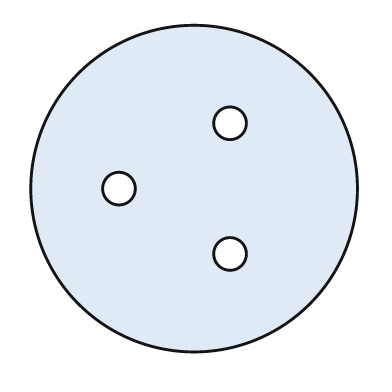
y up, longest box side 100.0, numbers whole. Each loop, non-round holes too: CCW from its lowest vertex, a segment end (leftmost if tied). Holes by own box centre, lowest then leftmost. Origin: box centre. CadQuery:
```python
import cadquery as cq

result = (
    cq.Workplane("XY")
    .moveTo(0.0, 0.0)
    .circle(50.0)
    .moveTo(11.0, -20.0)
    .circle(5.0)
    .moveTo(-23.0, 0.0)
    .circle(5.0)
    .moveTo(11.0, 20.0)
    .circle(5.0)
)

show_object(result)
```